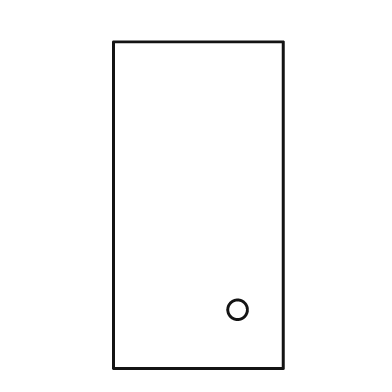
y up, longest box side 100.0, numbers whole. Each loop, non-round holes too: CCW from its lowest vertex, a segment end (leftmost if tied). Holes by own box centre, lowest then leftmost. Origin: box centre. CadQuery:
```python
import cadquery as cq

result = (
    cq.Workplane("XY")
    .moveTo(-26.0, -50.0)
    .lineTo(26.0, -50.0)
    .lineTo(26.0, 50.0)
    .lineTo(-26.0, 50.0)
    .close()
    .moveTo(12.0, -32.0)
    .circle(3.0)
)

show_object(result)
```